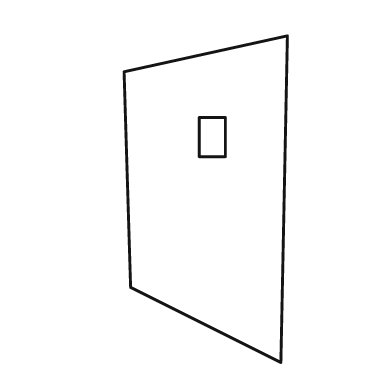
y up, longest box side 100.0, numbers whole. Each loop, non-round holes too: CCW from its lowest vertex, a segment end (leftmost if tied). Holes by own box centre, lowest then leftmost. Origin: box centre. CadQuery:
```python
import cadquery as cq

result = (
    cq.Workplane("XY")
    .moveTo(23.0, -50.0)
    .lineTo(25.0, 50.0)
    .lineTo(-25.0, 39.0)
    .lineTo(-23.0, -27.0)
    .close()
    .moveTo(-2.0, 13.0)
    .lineTo(6.0, 13.0)
    .lineTo(6.0, 25.0)
    .lineTo(-2.0, 25.0)
    .close()
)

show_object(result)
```